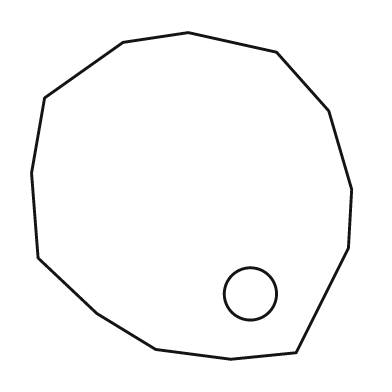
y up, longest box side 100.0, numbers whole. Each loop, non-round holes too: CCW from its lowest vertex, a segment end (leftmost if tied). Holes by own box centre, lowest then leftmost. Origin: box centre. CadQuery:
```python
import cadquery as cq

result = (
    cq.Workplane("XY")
    .moveTo(12.0, -50.0)
    .lineTo(32.0, -48.0)
    .lineTo(48.0, -16.0)
    .lineTo(49.0, 2.0)
    .lineTo(42.0, 26.0)
    .lineTo(26.0, 44.0)
    .lineTo(-1.0, 50.0)
    .lineTo(-21.0, 47.0)
    .lineTo(-45.0, 30.0)
    .lineTo(-49.0, 7.0)
    .lineTo(-47.0, -19.0)
    .lineTo(-29.0, -36.0)
    .lineTo(-11.0, -47.0)
    .close()
    .moveTo(18.0, -30.0)
    .circle(8.0)
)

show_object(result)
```